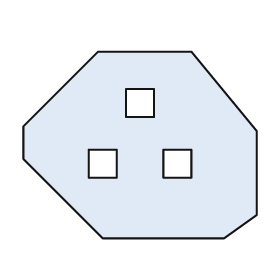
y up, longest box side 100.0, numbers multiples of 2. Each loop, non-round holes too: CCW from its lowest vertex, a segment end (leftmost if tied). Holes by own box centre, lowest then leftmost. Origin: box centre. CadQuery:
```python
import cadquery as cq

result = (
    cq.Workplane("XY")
    .moveTo(-16.0, -40.0)
    .lineTo(36.0, -40.0)
    .lineTo(50.0, -30.0)
    .lineTo(50.0, 6.0)
    .lineTo(22.0, 40.0)
    .lineTo(-18.0, 40.0)
    .lineTo(-50.0, 8.0)
    .lineTo(-50.0, -6.0)
    .close()
    .moveTo(-22.0, -14.0)
    .lineTo(-10.0, -14.0)
    .lineTo(-10.0, -2.0)
    .lineTo(-22.0, -2.0)
    .close()
    .moveTo(10.0, -14.0)
    .lineTo(22.0, -14.0)
    .lineTo(22.0, -2.0)
    .lineTo(10.0, -2.0)
    .close()
    .moveTo(-6.0, 12.0)
    .lineTo(6.0, 12.0)
    .lineTo(6.0, 24.0)
    .lineTo(-6.0, 24.0)
    .close()
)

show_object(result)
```